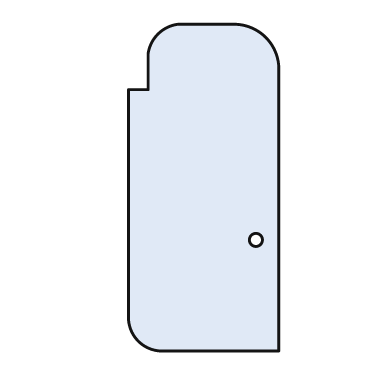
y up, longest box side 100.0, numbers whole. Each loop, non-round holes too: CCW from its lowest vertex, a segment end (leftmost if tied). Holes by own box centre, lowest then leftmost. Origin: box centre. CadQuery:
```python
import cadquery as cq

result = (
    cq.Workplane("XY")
    .moveTo(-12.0, -50.0)
    .lineTo(23.0, -50.0)
    .lineTo(23.0, 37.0)
    .threePointArc((19.0, 46.0), (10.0, 50.0))
    .lineTo(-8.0, 50.0)
    .threePointArc((-14.0, 47.0), (-17.0, 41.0))
    .lineTo(-17.0, 30.0)
    .lineTo(-23.0, 30.0)
    .lineTo(-23.0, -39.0)
    .threePointArc((-20.0, -47.0), (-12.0, -50.0))
    .close()
    .moveTo(16.0, -16.0)
    .circle(2.0)
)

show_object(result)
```